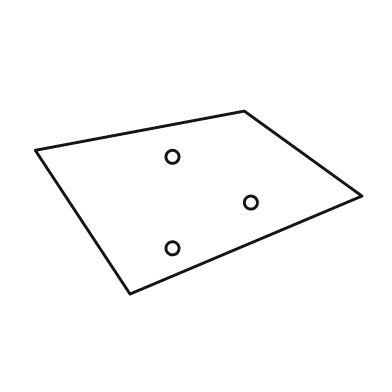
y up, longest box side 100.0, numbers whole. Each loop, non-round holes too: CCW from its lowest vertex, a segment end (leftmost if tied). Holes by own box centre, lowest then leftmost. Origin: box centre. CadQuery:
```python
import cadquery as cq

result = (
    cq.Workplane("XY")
    .moveTo(-21.0, -28.0)
    .lineTo(50.0, 2.0)
    .lineTo(14.0, 28.0)
    .lineTo(-50.0, 16.0)
    .close()
    .moveTo(-8.0, -14.0)
    .circle(2.0)
    .moveTo(16.0, 0.0)
    .circle(2.0)
    .moveTo(-8.0, 14.0)
    .circle(2.0)
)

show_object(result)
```